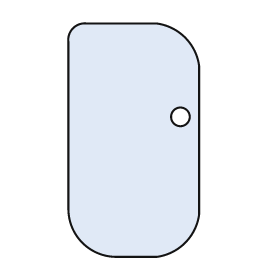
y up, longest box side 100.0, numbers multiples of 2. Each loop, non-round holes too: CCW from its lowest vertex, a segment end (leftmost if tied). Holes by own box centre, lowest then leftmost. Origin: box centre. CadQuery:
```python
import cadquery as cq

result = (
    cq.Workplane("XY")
    .moveTo(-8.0, -50.0)
    .lineTo(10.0, -50.0)
    .threePointArc((22.0, -44.0), (28.0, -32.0))
    .lineTo(28.0, 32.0)
    .threePointArc((22.0, 44.0), (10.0, 50.0))
    .lineTo(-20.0, 50.0)
    .threePointArc((-26.0, 48.0), (-28.0, 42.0))
    .lineTo(-28.0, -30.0)
    .threePointArc((-22.0, -44.0), (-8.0, -50.0))
    .close()
    .moveTo(20.0, 10.0)
    .circle(4.0)
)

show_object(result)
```